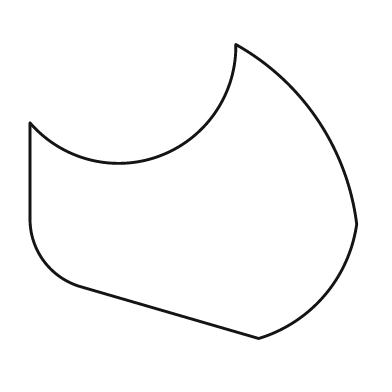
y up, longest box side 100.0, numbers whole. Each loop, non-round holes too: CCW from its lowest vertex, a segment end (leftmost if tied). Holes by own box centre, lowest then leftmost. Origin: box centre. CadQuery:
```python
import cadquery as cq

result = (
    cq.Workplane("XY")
    .moveTo(20.0, -45.0)
    .threePointArc((40.0, -32.0), (50.0, -10.0))
    .threePointArc((38.0, 22.0), (13.0, 45.0))
    .threePointArc((-10.0, 11.0), (-50.0, 21.0))
    .lineTo(-50.0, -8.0)
    .threePointArc((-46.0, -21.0), (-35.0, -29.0))
    .close()
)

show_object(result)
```